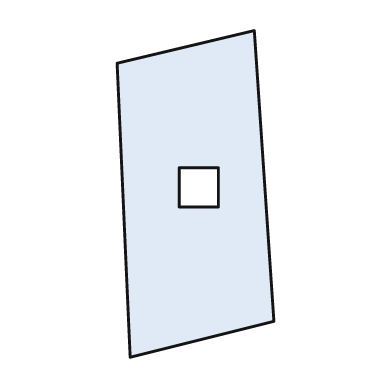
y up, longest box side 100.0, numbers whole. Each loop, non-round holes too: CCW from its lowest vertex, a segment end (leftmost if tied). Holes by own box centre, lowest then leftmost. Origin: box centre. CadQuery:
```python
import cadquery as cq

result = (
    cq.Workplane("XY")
    .moveTo(-20.0, -50.0)
    .lineTo(24.0, -39.0)
    .lineTo(18.0, 50.0)
    .lineTo(-24.0, 40.0)
    .close()
    .moveTo(-5.0, -4.0)
    .lineTo(7.0, -4.0)
    .lineTo(7.0, 8.0)
    .lineTo(-5.0, 8.0)
    .close()
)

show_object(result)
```